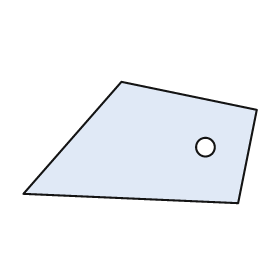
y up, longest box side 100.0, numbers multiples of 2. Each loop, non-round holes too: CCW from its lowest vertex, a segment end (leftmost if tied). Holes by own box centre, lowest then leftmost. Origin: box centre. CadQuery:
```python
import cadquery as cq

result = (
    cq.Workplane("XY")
    .moveTo(42.0, -26.0)
    .lineTo(50.0, 14.0)
    .lineTo(-8.0, 26.0)
    .lineTo(-50.0, -22.0)
    .close()
    .moveTo(28.0, -2.0)
    .circle(4.0)
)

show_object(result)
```